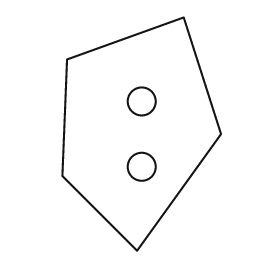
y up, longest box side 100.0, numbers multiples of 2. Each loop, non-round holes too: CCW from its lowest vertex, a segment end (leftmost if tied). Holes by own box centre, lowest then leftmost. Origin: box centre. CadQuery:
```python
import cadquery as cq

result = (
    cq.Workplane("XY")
    .moveTo(-2.0, -50.0)
    .lineTo(34.0, 0.0)
    .lineTo(18.0, 50.0)
    .lineTo(-32.0, 32.0)
    .lineTo(-34.0, -18.0)
    .close()
    .moveTo(0.0, -14.0)
    .circle(6.0)
    .moveTo(0.0, 14.0)
    .circle(6.0)
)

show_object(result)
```